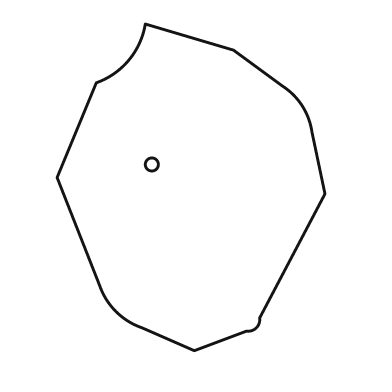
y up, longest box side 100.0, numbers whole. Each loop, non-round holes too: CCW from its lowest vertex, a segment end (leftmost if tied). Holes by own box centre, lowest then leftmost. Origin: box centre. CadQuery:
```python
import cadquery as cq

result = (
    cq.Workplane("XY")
    .moveTo(1.0, -50.0)
    .lineTo(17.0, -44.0)
    .threePointArc((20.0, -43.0), (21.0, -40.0))
    .lineTo(41.0, -2.0)
    .lineTo(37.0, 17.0)
    .threePointArc((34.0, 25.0), (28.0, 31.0))
    .lineTo(13.0, 42.0)
    .lineTo(-14.0, 50.0)
    .threePointArc((-19.0, 39.0), (-29.0, 32.0))
    .lineTo(-41.0, 3.0)
    .lineTo(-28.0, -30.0)
    .threePointArc((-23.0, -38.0), (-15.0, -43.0))
    .close()
    .moveTo(-12.0, 7.0)
    .circle(2.0)
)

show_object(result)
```